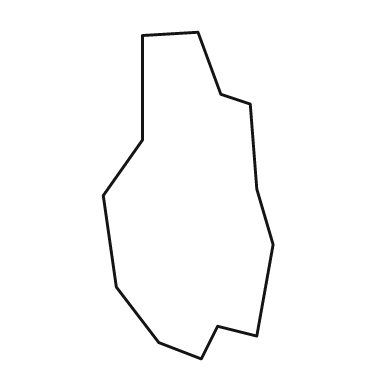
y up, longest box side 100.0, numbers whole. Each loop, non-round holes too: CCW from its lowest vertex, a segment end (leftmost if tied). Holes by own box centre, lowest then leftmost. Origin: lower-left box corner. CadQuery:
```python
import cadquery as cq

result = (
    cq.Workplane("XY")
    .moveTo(30.0, 0.0)
    .lineTo(35.0, 10.0)
    .lineTo(47.0, 7.0)
    .lineTo(52.0, 35.0)
    .lineTo(47.0, 52.0)
    .lineTo(45.0, 78.0)
    .lineTo(36.0, 81.0)
    .lineTo(29.0, 100.0)
    .lineTo(12.0, 99.0)
    .lineTo(12.0, 67.0)
    .lineTo(0.0, 50.0)
    .lineTo(4.0, 22.0)
    .lineTo(17.0, 5.0)
    .close()
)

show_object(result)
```